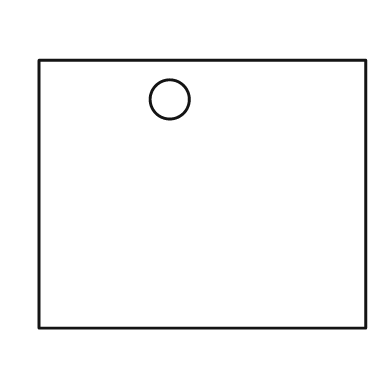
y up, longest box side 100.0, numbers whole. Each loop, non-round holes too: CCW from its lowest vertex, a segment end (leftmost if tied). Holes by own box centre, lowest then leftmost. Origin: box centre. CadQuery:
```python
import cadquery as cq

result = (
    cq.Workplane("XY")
    .moveTo(-50.0, -41.0)
    .lineTo(50.0, -41.0)
    .lineTo(50.0, 41.0)
    .lineTo(-50.0, 41.0)
    .close()
    .moveTo(-10.0, 29.0)
    .circle(6.0)
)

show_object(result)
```